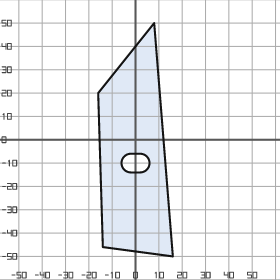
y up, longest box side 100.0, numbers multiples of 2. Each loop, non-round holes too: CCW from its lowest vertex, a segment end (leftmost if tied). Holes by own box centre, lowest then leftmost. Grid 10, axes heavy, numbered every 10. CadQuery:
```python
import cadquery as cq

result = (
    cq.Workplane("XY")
    .moveTo(16.0, -50.0)
    .lineTo(8.0, 50.0)
    .lineTo(-16.0, 20.0)
    .lineTo(-14.0, -46.0)
    .close()
    .moveTo(-2.0, -14.0)
    .lineTo(2.0, -14.0)
    .threePointArc((6.0, -10.0), (2.0, -6.0))
    .lineTo(-2.0, -6.0)
    .threePointArc((-6.0, -10.0), (-2.0, -14.0))
    .close()
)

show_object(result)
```